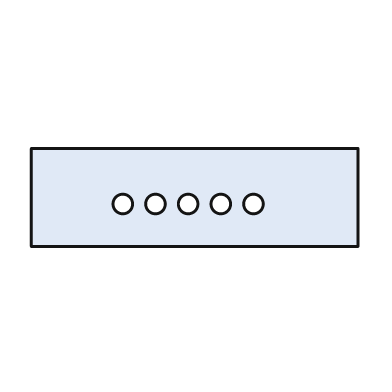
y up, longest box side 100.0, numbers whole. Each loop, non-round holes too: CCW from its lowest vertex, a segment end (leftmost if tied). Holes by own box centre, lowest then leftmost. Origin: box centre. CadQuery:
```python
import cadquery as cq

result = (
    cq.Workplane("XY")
    .moveTo(-50.0, -15.0)
    .lineTo(50.0, -15.0)
    .lineTo(50.0, 15.0)
    .lineTo(-50.0, 15.0)
    .close()
    .moveTo(-22.0, -2.0)
    .circle(3.0)
    .moveTo(-12.0, -2.0)
    .circle(3.0)
    .moveTo(-2.0, -2.0)
    .circle(3.0)
    .moveTo(8.0, -2.0)
    .circle(3.0)
    .moveTo(18.0, -2.0)
    .circle(3.0)
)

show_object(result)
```